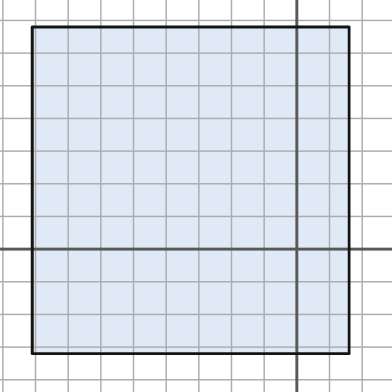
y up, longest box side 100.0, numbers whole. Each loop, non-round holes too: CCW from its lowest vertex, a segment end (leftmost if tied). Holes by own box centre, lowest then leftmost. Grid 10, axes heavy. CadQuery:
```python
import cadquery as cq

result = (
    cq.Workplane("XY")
    .moveTo(-81.0, -32.0)
    .lineTo(16.0, -32.0)
    .lineTo(16.0, 68.0)
    .lineTo(-81.0, 68.0)
    .close()
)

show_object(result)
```